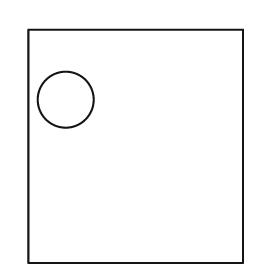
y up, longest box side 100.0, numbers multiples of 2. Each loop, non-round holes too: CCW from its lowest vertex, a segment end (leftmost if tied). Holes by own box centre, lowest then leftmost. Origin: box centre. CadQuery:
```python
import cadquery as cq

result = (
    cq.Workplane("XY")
    .moveTo(-46.0, -50.0)
    .lineTo(46.0, -50.0)
    .lineTo(46.0, 50.0)
    .lineTo(-46.0, 50.0)
    .close()
    .moveTo(-30.0, 20.0)
    .circle(12.0)
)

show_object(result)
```